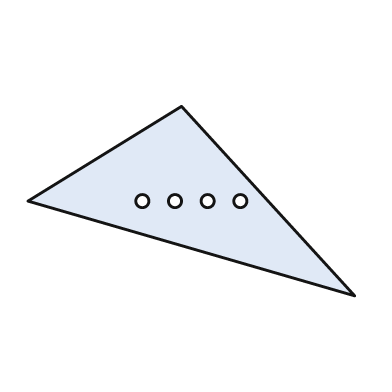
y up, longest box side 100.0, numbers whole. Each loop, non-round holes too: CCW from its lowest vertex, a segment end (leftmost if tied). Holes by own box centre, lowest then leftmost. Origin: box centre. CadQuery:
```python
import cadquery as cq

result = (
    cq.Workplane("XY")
    .moveTo(50.0, -29.0)
    .lineTo(-3.0, 29.0)
    .lineTo(-50.0, 0.0)
    .close()
    .moveTo(-15.0, 0.0)
    .circle(2.0)
    .moveTo(-5.0, 0.0)
    .circle(2.0)
    .moveTo(5.0, 0.0)
    .circle(2.0)
    .moveTo(15.0, 0.0)
    .circle(2.0)
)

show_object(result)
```